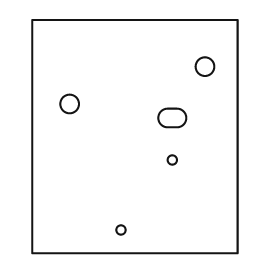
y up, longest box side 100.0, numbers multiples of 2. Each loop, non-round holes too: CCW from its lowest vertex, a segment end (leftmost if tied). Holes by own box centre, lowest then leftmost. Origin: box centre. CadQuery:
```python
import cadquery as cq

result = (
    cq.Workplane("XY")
    .moveTo(-44.0, -50.0)
    .lineTo(44.0, -50.0)
    .lineTo(44.0, 50.0)
    .lineTo(-44.0, 50.0)
    .close()
    .moveTo(-6.0, -40.0)
    .circle(2.0)
    .moveTo(16.0, -10.0)
    .circle(2.0)
    .moveTo(14.0, 4.0)
    .lineTo(18.0, 4.0)
    .threePointArc((22.0, 8.0), (18.0, 12.0))
    .lineTo(14.0, 12.0)
    .threePointArc((10.0, 8.0), (14.0, 4.0))
    .close()
    .moveTo(-28.0, 14.0)
    .circle(4.0)
    .moveTo(30.0, 30.0)
    .circle(4.0)
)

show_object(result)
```